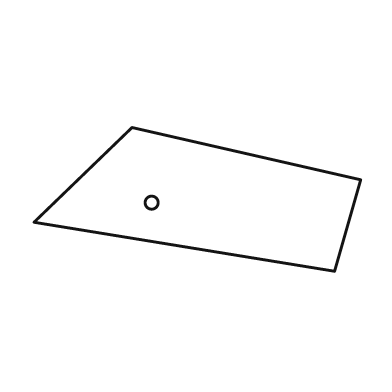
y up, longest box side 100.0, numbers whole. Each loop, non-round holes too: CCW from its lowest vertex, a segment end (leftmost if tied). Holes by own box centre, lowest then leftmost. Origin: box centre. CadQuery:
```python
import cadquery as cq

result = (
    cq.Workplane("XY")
    .moveTo(42.0, -22.0)
    .lineTo(50.0, 6.0)
    .lineTo(-20.0, 22.0)
    .lineTo(-50.0, -7.0)
    .close()
    .moveTo(-14.0, -1.0)
    .circle(2.0)
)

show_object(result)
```